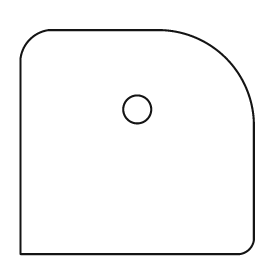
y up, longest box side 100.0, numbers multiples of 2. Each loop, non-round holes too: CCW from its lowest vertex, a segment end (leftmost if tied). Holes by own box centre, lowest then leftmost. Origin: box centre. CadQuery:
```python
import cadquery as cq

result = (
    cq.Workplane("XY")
    .moveTo(-50.0, -48.0)
    .lineTo(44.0, -48.0)
    .threePointArc((48.0, -46.0), (50.0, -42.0))
    .lineTo(50.0, 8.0)
    .threePointArc((38.0, 36.0), (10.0, 48.0))
    .lineTo(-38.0, 48.0)
    .threePointArc((-46.0, 44.0), (-50.0, 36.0))
    .close()
    .moveTo(0.0, 14.0)
    .circle(6.0)
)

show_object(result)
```